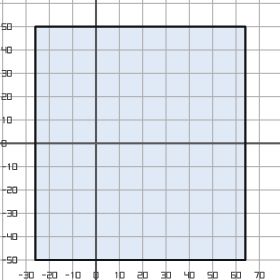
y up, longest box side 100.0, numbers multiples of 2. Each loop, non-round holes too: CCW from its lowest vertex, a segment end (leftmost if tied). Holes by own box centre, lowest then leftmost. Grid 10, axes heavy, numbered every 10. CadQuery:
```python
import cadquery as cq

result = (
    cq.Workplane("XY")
    .moveTo(-26.0, -50.0)
    .lineTo(64.0, -50.0)
    .lineTo(64.0, 50.0)
    .lineTo(-26.0, 50.0)
    .close()
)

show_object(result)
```